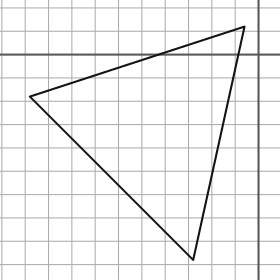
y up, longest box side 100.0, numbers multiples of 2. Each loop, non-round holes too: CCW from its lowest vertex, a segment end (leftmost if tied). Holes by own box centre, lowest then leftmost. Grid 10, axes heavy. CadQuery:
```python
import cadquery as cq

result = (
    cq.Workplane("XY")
    .moveTo(-28.0, -88.0)
    .lineTo(-6.0, 12.0)
    .lineTo(-98.0, -18.0)
    .close()
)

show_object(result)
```